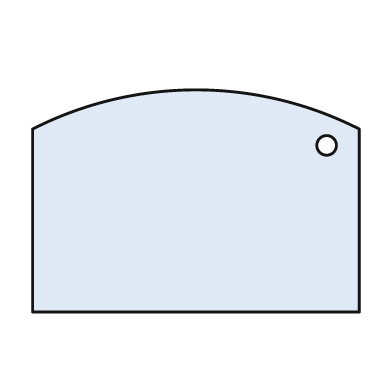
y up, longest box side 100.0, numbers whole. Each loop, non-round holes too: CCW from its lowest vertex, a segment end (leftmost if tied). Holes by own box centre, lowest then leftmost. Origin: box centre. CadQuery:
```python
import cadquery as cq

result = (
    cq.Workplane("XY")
    .moveTo(-50.0, -34.0)
    .lineTo(50.0, -34.0)
    .lineTo(50.0, 22.0)
    .threePointArc((0.0, 34.0), (-50.0, 22.0))
    .close()
    .moveTo(40.0, 17.0)
    .circle(3.0)
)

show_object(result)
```